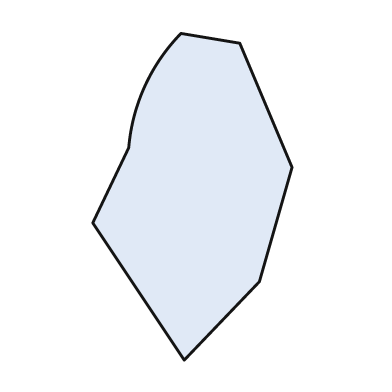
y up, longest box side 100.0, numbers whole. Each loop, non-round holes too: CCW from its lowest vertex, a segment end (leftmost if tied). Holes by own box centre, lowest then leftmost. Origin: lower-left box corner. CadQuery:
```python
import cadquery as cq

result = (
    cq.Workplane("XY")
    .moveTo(28.0, 0.0)
    .lineTo(51.0, 24.0)
    .lineTo(61.0, 59.0)
    .lineTo(45.0, 97.0)
    .lineTo(27.0, 100.0)
    .threePointArc((16.0, 84.0), (11.0, 65.0))
    .lineTo(0.0, 42.0)
    .close()
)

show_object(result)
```